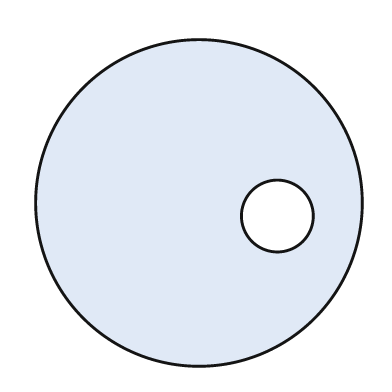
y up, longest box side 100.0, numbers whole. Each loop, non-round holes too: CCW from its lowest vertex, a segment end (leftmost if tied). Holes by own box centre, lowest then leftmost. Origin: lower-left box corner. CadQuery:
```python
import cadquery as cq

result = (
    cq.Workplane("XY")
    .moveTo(50.0, 50.0)
    .circle(50.0)
    .moveTo(74.0, 46.0)
    .circle(11.0)
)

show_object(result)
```